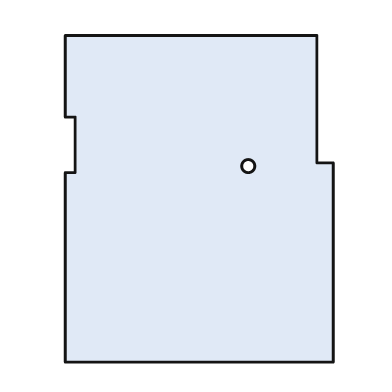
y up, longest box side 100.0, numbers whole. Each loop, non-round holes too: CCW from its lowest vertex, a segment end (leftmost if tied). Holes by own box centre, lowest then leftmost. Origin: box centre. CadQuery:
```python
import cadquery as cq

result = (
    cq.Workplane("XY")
    .moveTo(-41.0, -50.0)
    .lineTo(41.0, -50.0)
    .lineTo(41.0, 11.0)
    .lineTo(36.0, 11.0)
    .lineTo(36.0, 50.0)
    .lineTo(-41.0, 50.0)
    .lineTo(-41.0, 25.0)
    .lineTo(-38.0, 25.0)
    .lineTo(-38.0, 8.0)
    .lineTo(-41.0, 8.0)
    .close()
    .moveTo(15.0, 10.0)
    .circle(2.0)
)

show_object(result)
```